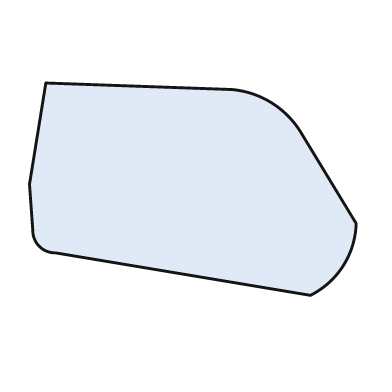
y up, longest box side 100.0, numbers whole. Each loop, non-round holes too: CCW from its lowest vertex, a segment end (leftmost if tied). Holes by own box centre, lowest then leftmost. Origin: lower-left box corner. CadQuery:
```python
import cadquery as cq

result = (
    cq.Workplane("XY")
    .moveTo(86.0, 0.0)
    .threePointArc((96.0, 9.0), (100.0, 22.0))
    .lineTo(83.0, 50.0)
    .threePointArc((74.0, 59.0), (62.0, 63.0))
    .lineTo(5.0, 65.0)
    .lineTo(0.0, 34.0)
    .lineTo(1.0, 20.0)
    .threePointArc((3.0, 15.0), (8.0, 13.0))
    .close()
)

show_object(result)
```